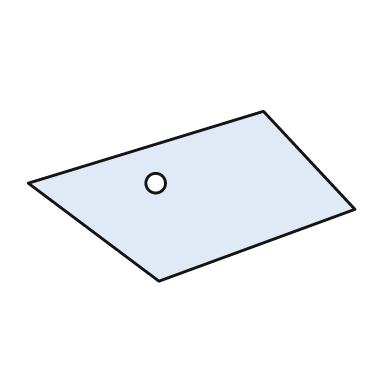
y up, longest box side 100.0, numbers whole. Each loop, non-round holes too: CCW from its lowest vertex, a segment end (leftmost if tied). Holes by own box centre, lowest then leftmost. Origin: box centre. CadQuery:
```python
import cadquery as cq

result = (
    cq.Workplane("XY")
    .moveTo(-10.0, -26.0)
    .lineTo(50.0, -4.0)
    .lineTo(22.0, 26.0)
    .lineTo(-50.0, 4.0)
    .close()
    .moveTo(-11.0, 4.0)
    .circle(3.0)
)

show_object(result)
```